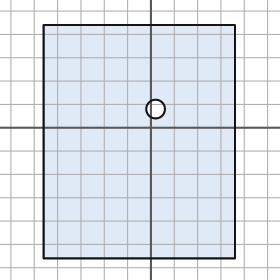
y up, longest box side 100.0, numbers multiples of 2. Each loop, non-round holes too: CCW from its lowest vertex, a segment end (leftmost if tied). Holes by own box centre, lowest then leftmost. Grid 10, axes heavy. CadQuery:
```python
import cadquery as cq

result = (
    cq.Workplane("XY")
    .moveTo(-46.0, -56.0)
    .lineTo(36.0, -56.0)
    .lineTo(36.0, 44.0)
    .lineTo(-46.0, 44.0)
    .close()
    .moveTo(2.0, 8.0)
    .circle(4.0)
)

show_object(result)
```